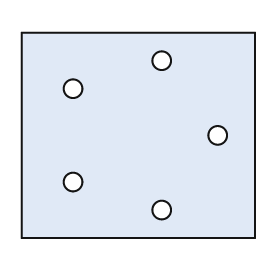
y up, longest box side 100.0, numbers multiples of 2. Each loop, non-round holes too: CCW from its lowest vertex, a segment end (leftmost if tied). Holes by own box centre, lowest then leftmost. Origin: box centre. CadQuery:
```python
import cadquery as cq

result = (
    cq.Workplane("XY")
    .moveTo(-50.0, -44.0)
    .lineTo(50.0, -44.0)
    .lineTo(50.0, 44.0)
    .lineTo(-50.0, 44.0)
    .close()
    .moveTo(10.0, -32.0)
    .circle(4.0)
    .moveTo(-28.0, -20.0)
    .circle(4.0)
    .moveTo(34.0, 0.0)
    .circle(4.0)
    .moveTo(-28.0, 20.0)
    .circle(4.0)
    .moveTo(10.0, 32.0)
    .circle(4.0)
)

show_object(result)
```